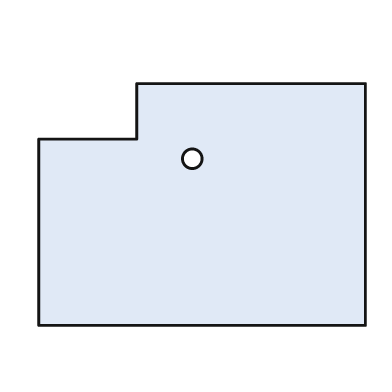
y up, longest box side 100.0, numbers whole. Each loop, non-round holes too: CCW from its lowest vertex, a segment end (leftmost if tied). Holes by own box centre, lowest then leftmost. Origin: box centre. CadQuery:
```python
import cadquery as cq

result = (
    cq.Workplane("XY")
    .moveTo(-50.0, -37.0)
    .lineTo(50.0, -37.0)
    .lineTo(50.0, 37.0)
    .lineTo(-20.0, 37.0)
    .lineTo(-20.0, 20.0)
    .lineTo(-50.0, 20.0)
    .close()
    .moveTo(-3.0, 14.0)
    .circle(3.0)
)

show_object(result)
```